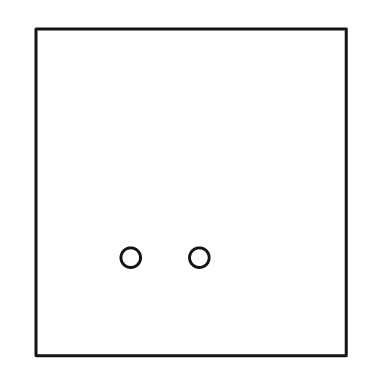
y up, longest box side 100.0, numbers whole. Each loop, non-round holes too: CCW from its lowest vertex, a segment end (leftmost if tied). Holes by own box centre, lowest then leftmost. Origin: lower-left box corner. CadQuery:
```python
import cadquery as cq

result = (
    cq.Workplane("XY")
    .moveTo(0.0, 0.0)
    .lineTo(95.0, 0.0)
    .lineTo(95.0, 100.0)
    .lineTo(0.0, 100.0)
    .close()
    .moveTo(29.0, 30.0)
    .circle(3.0)
    .moveTo(50.0, 30.0)
    .circle(3.0)
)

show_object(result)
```